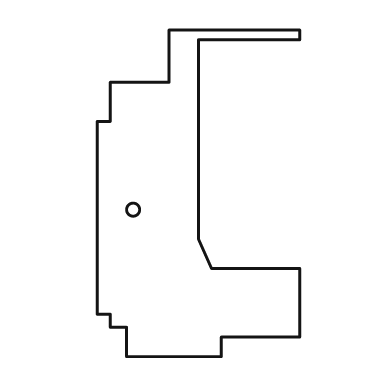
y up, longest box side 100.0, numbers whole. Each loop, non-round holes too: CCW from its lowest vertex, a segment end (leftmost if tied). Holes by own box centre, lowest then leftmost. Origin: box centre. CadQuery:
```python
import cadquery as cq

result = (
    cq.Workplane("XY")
    .moveTo(-22.0, -50.0)
    .lineTo(7.0, -50.0)
    .lineTo(7.0, -44.0)
    .lineTo(31.0, -44.0)
    .lineTo(31.0, -23.0)
    .lineTo(4.0, -23.0)
    .lineTo(0.0, -14.0)
    .lineTo(0.0, 47.0)
    .lineTo(31.0, 47.0)
    .lineTo(31.0, 50.0)
    .lineTo(-9.0, 50.0)
    .lineTo(-9.0, 34.0)
    .lineTo(-27.0, 34.0)
    .lineTo(-27.0, 22.0)
    .lineTo(-31.0, 22.0)
    .lineTo(-31.0, -37.0)
    .lineTo(-27.0, -37.0)
    .lineTo(-27.0, -41.0)
    .lineTo(-22.0, -41.0)
    .close()
    .moveTo(-20.0, -5.0)
    .circle(2.0)
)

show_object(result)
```